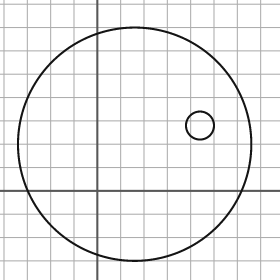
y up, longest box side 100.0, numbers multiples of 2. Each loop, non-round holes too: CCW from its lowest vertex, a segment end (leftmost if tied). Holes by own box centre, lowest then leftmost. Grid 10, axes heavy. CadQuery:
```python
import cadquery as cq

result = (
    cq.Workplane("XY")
    .moveTo(16.0, 20.0)
    .circle(50.0)
    .moveTo(44.0, 28.0)
    .circle(6.0)
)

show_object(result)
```